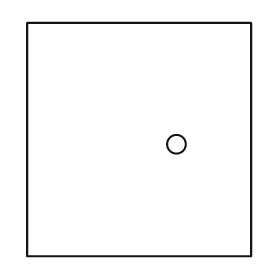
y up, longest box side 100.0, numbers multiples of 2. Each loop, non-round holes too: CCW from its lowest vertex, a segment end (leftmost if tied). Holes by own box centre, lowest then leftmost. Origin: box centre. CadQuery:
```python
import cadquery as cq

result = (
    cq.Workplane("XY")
    .moveTo(-48.0, -50.0)
    .lineTo(48.0, -50.0)
    .lineTo(48.0, 50.0)
    .lineTo(-48.0, 50.0)
    .close()
    .moveTo(16.0, -2.0)
    .circle(4.0)
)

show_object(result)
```